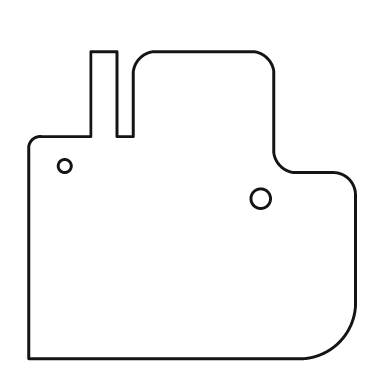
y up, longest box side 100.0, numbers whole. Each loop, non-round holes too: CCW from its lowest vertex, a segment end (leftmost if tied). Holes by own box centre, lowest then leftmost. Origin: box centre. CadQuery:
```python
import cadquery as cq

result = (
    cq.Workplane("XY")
    .moveTo(-50.0, -47.0)
    .lineTo(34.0, -47.0)
    .threePointArc((45.0, -42.0), (50.0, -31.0))
    .lineTo(50.0, 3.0)
    .threePointArc((48.0, 8.0), (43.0, 10.0))
    .lineTo(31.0, 10.0)
    .threePointArc((27.0, 12.0), (25.0, 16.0))
    .lineTo(25.0, 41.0)
    .threePointArc((23.0, 45.0), (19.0, 47.0))
    .lineTo(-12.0, 47.0)
    .threePointArc((-16.0, 45.0), (-18.0, 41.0))
    .lineTo(-18.0, 21.0)
    .lineTo(-23.0, 21.0)
    .lineTo(-23.0, 47.0)
    .lineTo(-31.0, 47.0)
    .lineTo(-31.0, 21.0)
    .lineTo(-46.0, 21.0)
    .threePointArc((-49.0, 20.0), (-50.0, 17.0))
    .close()
    .moveTo(21.0, 2.0)
    .circle(3.0)
    .moveTo(-39.0, 12.0)
    .circle(2.0)
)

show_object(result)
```